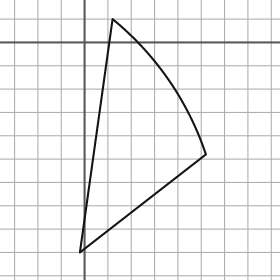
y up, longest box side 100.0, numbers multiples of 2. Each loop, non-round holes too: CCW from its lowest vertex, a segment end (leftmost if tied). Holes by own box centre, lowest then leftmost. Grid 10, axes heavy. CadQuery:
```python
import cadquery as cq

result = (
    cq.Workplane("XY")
    .moveTo(-2.0, -90.0)
    .lineTo(52.0, -48.0)
    .threePointArc((36.0, -16.0), (12.0, 10.0))
    .close()
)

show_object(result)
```